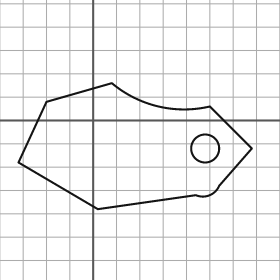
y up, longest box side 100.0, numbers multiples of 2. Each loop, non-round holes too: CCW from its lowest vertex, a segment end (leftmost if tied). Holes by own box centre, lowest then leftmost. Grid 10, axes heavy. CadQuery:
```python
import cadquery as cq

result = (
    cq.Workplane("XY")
    .moveTo(2.0, -38.0)
    .lineTo(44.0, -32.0)
    .threePointArc((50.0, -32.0), (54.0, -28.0))
    .lineTo(68.0, -12.0)
    .lineTo(50.0, 6.0)
    .threePointArc((28.0, 6.0), (8.0, 16.0))
    .lineTo(-20.0, 8.0)
    .lineTo(-32.0, -18.0)
    .close()
    .moveTo(48.0, -12.0)
    .circle(6.0)
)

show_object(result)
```